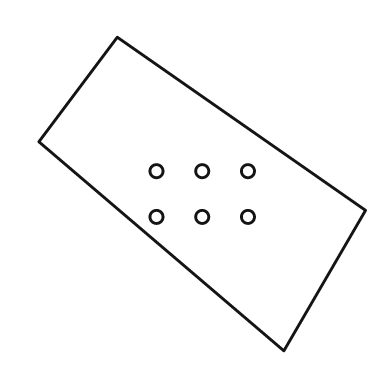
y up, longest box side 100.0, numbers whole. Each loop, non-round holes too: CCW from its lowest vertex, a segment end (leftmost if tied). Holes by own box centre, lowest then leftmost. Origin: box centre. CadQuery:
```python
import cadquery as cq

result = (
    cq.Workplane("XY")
    .moveTo(25.0, -48.0)
    .lineTo(50.0, -5.0)
    .lineTo(-26.0, 48.0)
    .lineTo(-50.0, 16.0)
    .close()
    .moveTo(-14.0, -7.0)
    .circle(2.0)
    .moveTo(0.0, -7.0)
    .circle(2.0)
    .moveTo(14.0, -7.0)
    .circle(2.0)
    .moveTo(-14.0, 7.0)
    .circle(2.0)
    .moveTo(0.0, 7.0)
    .circle(2.0)
    .moveTo(14.0, 7.0)
    .circle(2.0)
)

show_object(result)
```